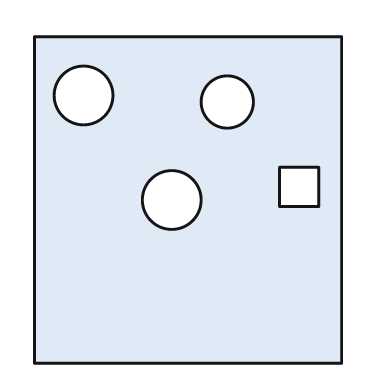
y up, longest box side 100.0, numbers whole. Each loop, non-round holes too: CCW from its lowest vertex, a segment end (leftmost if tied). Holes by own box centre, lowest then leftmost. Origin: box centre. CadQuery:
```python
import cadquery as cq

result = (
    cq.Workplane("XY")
    .moveTo(-47.0, -50.0)
    .lineTo(47.0, -50.0)
    .lineTo(47.0, 50.0)
    .lineTo(-47.0, 50.0)
    .close()
    .moveTo(-5.0, 0.0)
    .circle(9.0)
    .moveTo(28.0, -2.0)
    .lineTo(40.0, -2.0)
    .lineTo(40.0, 10.0)
    .lineTo(28.0, 10.0)
    .close()
    .moveTo(12.0, 30.0)
    .circle(8.0)
    .moveTo(-32.0, 32.0)
    .circle(9.0)
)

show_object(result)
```